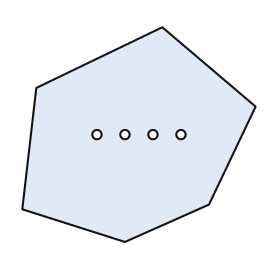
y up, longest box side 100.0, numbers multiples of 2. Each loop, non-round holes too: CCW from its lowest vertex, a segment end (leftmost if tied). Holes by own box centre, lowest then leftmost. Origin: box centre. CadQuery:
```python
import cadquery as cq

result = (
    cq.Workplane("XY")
    .moveTo(-6.0, -46.0)
    .lineTo(30.0, -30.0)
    .lineTo(50.0, 12.0)
    .lineTo(10.0, 46.0)
    .lineTo(-44.0, 20.0)
    .lineTo(-50.0, -32.0)
    .close()
    .moveTo(-18.0, 0.0)
    .circle(2.0)
    .moveTo(-6.0, 0.0)
    .circle(2.0)
    .moveTo(6.0, 0.0)
    .circle(2.0)
    .moveTo(18.0, 0.0)
    .circle(2.0)
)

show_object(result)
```